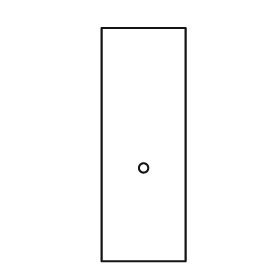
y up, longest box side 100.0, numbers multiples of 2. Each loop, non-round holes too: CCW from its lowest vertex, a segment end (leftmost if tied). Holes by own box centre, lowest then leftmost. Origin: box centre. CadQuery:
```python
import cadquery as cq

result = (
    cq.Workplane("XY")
    .moveTo(-18.0, -50.0)
    .lineTo(18.0, -50.0)
    .lineTo(18.0, 50.0)
    .lineTo(-18.0, 50.0)
    .close()
    .moveTo(0.0, -10.0)
    .circle(2.0)
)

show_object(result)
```